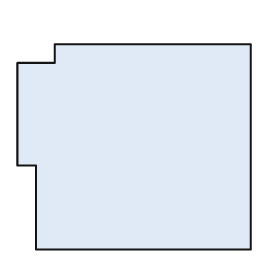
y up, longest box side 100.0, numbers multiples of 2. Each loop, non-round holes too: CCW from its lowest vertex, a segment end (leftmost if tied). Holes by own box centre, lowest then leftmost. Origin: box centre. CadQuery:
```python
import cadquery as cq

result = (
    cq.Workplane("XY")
    .moveTo(-42.0, -44.0)
    .lineTo(50.0, -44.0)
    .lineTo(50.0, 44.0)
    .lineTo(-34.0, 44.0)
    .lineTo(-34.0, 36.0)
    .lineTo(-50.0, 36.0)
    .lineTo(-50.0, -8.0)
    .lineTo(-42.0, -8.0)
    .close()
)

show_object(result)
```